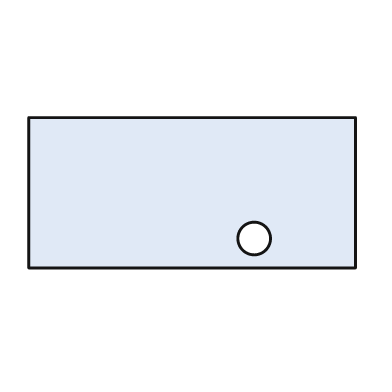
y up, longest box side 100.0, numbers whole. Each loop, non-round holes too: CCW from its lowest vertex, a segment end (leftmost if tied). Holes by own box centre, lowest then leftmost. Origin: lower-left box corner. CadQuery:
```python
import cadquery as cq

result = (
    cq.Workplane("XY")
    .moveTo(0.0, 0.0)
    .lineTo(100.0, 0.0)
    .lineTo(100.0, 46.0)
    .lineTo(0.0, 46.0)
    .close()
    .moveTo(69.0, 9.0)
    .circle(5.0)
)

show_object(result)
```